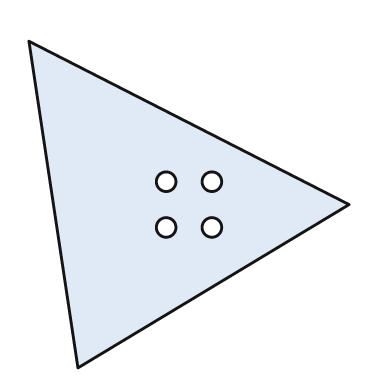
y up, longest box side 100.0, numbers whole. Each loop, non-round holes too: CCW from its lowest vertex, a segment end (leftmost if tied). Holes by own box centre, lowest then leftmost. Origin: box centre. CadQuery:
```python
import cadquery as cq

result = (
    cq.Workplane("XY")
    .moveTo(-34.0, -50.0)
    .lineTo(49.0, 0.0)
    .lineTo(-49.0, 50.0)
    .close()
    .moveTo(-7.0, -7.0)
    .circle(3.0)
    .moveTo(7.0, -7.0)
    .circle(3.0)
    .moveTo(-7.0, 7.0)
    .circle(3.0)
    .moveTo(7.0, 7.0)
    .circle(3.0)
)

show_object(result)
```